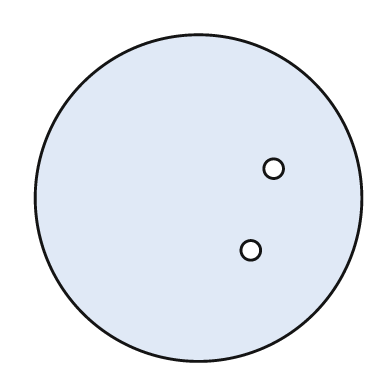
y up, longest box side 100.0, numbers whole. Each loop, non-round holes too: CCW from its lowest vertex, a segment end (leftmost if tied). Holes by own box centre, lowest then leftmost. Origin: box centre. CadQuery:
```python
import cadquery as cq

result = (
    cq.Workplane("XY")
    .moveTo(0.0, 0.0)
    .circle(50.0)
    .moveTo(16.0, -16.0)
    .circle(3.0)
    .moveTo(23.0, 9.0)
    .circle(3.0)
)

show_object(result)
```